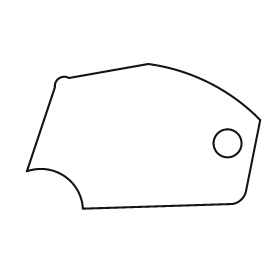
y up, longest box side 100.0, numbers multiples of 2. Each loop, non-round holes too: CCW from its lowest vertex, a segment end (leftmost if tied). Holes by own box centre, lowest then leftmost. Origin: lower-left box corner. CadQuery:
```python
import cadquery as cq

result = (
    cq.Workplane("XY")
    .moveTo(24.0, 0.0)
    .lineTo(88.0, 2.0)
    .threePointArc((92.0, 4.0), (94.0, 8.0))
    .lineTo(100.0, 38.0)
    .threePointArc((78.0, 54.0), (52.0, 62.0))
    .lineTo(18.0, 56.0)
    .threePointArc((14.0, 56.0), (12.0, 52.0))
    .lineTo(0.0, 16.0)
    .threePointArc((16.0, 14.0), (24.0, 0.0))
    .close()
    .moveTo(86.0, 28.0)
    .circle(6.0)
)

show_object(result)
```